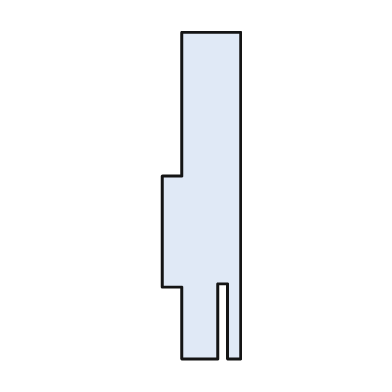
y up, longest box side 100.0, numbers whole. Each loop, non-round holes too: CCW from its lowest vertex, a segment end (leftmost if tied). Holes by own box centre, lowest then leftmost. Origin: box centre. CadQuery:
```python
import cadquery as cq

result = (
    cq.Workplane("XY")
    .moveTo(-6.0, -50.0)
    .lineTo(5.0, -50.0)
    .lineTo(5.0, -27.0)
    .lineTo(8.0, -27.0)
    .lineTo(8.0, -50.0)
    .lineTo(12.0, -50.0)
    .lineTo(12.0, 50.0)
    .lineTo(-6.0, 50.0)
    .lineTo(-6.0, 6.0)
    .lineTo(-12.0, 6.0)
    .lineTo(-12.0, -28.0)
    .lineTo(-6.0, -28.0)
    .close()
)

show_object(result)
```